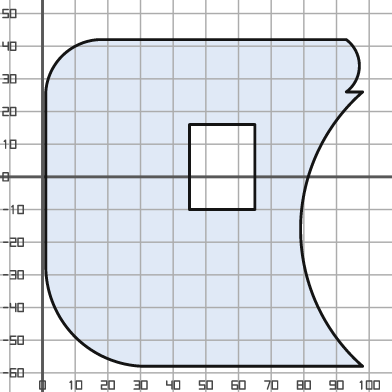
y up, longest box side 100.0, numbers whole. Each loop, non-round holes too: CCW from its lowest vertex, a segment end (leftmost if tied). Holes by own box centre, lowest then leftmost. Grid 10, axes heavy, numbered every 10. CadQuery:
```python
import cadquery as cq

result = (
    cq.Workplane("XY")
    .moveTo(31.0, -58.0)
    .lineTo(98.0, -58.0)
    .threePointArc((79.0, -16.0), (98.0, 26.0))
    .lineTo(93.0, 26.0)
    .threePointArc((97.0, 34.0), (93.0, 42.0))
    .lineTo(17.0, 42.0)
    .threePointArc((6.0, 37.0), (1.0, 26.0))
    .lineTo(1.0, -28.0)
    .threePointArc((10.0, -49.0), (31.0, -58.0))
    .close()
    .moveTo(45.0, -10.0)
    .lineTo(65.0, -10.0)
    .lineTo(65.0, 16.0)
    .lineTo(45.0, 16.0)
    .close()
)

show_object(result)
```